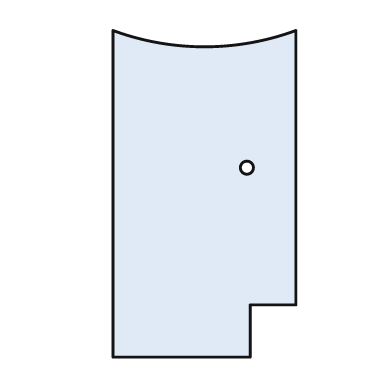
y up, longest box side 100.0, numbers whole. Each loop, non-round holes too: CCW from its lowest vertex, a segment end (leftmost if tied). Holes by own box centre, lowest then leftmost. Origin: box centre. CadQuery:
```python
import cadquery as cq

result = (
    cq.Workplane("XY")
    .moveTo(-28.0, -50.0)
    .lineTo(14.0, -50.0)
    .lineTo(14.0, -34.0)
    .lineTo(28.0, -34.0)
    .lineTo(28.0, 50.0)
    .threePointArc((0.0, 45.0), (-28.0, 50.0))
    .close()
    .moveTo(13.0, 8.0)
    .circle(2.0)
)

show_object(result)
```